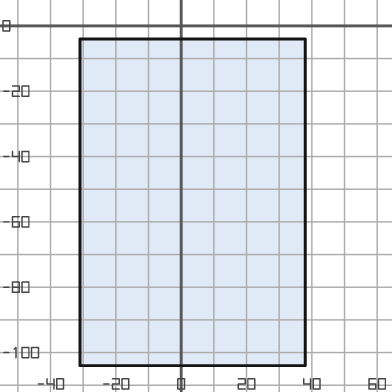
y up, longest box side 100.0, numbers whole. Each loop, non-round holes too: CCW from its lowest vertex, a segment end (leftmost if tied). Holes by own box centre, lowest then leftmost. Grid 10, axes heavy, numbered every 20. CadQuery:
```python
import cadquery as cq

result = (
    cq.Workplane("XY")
    .moveTo(-31.0, -104.0)
    .lineTo(38.0, -104.0)
    .lineTo(38.0, -4.0)
    .lineTo(-31.0, -4.0)
    .close()
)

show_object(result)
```